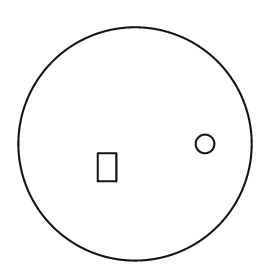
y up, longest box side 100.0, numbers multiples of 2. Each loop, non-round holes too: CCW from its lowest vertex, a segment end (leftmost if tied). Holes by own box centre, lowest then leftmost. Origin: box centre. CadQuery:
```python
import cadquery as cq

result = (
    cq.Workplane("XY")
    .moveTo(0.0, 0.0)
    .circle(50.0)
    .moveTo(-16.0, -16.0)
    .lineTo(-8.0, -16.0)
    .lineTo(-8.0, -4.0)
    .lineTo(-16.0, -4.0)
    .close()
    .moveTo(30.0, 0.0)
    .circle(4.0)
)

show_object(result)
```